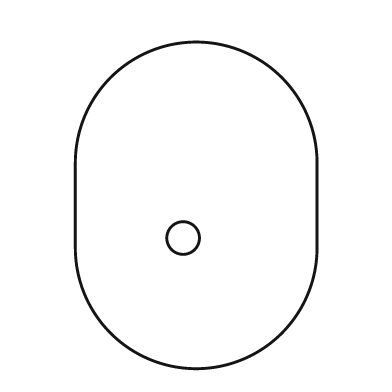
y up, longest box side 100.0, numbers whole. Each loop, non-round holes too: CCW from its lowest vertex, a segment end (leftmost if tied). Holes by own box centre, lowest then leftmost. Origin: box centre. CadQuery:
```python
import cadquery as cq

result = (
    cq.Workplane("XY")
    .moveTo(-37.0, -13.0)
    .threePointArc((0.0, -50.0), (37.0, -13.0))
    .lineTo(37.0, 13.0)
    .threePointArc((0.0, 50.0), (-37.0, 13.0))
    .close()
    .moveTo(-4.0, -10.0)
    .circle(5.0)
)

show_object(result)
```